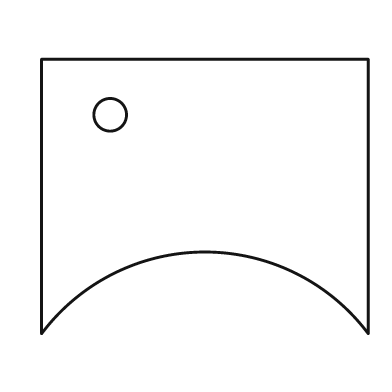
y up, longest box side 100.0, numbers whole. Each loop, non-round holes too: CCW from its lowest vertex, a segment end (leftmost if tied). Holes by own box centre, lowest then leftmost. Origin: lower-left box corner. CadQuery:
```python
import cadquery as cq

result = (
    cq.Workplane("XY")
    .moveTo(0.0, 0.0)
    .threePointArc((50.0, 25.0), (100.0, 0.0))
    .lineTo(100.0, 84.0)
    .lineTo(0.0, 84.0)
    .close()
    .moveTo(21.0, 67.0)
    .circle(5.0)
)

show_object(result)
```